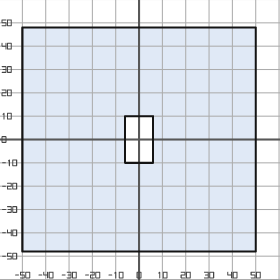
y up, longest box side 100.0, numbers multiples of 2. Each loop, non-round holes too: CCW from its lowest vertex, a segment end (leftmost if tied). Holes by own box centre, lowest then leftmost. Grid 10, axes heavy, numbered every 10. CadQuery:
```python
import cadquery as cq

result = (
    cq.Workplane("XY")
    .moveTo(-50.0, -48.0)
    .lineTo(50.0, -48.0)
    .lineTo(50.0, 48.0)
    .lineTo(-50.0, 48.0)
    .close()
    .moveTo(-6.0, -10.0)
    .lineTo(6.0, -10.0)
    .lineTo(6.0, 10.0)
    .lineTo(-6.0, 10.0)
    .close()
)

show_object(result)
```